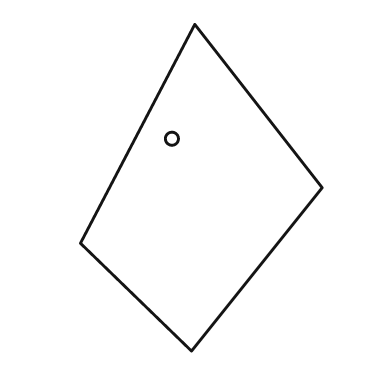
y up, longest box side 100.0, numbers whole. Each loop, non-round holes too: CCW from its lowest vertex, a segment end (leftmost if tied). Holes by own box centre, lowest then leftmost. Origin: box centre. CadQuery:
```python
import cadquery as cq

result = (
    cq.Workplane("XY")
    .moveTo(-3.0, -50.0)
    .lineTo(37.0, 0.0)
    .lineTo(-2.0, 50.0)
    .lineTo(-37.0, -17.0)
    .close()
    .moveTo(-9.0, 15.0)
    .circle(2.0)
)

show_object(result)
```